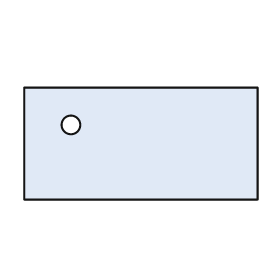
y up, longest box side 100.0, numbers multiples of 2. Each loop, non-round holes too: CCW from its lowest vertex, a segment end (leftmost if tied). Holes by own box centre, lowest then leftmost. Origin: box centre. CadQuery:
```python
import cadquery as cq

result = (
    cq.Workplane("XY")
    .moveTo(-50.0, -24.0)
    .lineTo(50.0, -24.0)
    .lineTo(50.0, 24.0)
    .lineTo(-50.0, 24.0)
    .close()
    .moveTo(-30.0, 8.0)
    .circle(4.0)
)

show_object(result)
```